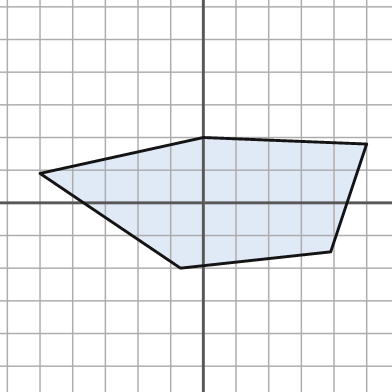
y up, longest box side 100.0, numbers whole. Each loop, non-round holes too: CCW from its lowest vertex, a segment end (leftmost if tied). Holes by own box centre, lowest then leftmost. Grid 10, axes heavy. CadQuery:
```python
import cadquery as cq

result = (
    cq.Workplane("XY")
    .moveTo(-7.0, -20.0)
    .lineTo(39.0, -15.0)
    .lineTo(50.0, 18.0)
    .lineTo(0.0, 20.0)
    .lineTo(-50.0, 9.0)
    .close()
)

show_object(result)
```